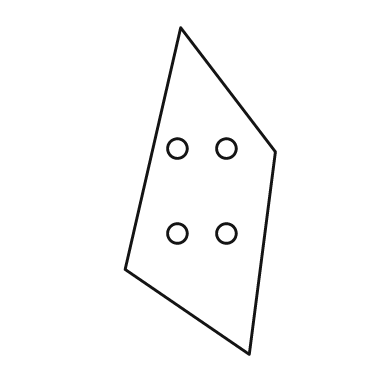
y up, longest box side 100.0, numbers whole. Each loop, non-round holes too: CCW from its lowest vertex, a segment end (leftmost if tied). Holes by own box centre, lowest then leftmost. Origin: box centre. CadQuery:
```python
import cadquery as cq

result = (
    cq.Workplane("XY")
    .moveTo(15.0, -50.0)
    .lineTo(23.0, 12.0)
    .lineTo(-6.0, 50.0)
    .lineTo(-23.0, -24.0)
    .close()
    .moveTo(-7.0, -13.0)
    .circle(3.0)
    .moveTo(8.0, -13.0)
    .circle(3.0)
    .moveTo(-7.0, 13.0)
    .circle(3.0)
    .moveTo(8.0, 13.0)
    .circle(3.0)
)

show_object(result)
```